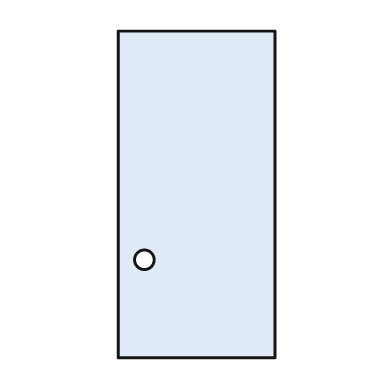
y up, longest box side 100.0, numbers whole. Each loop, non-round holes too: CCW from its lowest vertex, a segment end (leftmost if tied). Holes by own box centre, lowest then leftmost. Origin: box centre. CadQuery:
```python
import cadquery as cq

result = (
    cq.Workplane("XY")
    .moveTo(-24.0, -50.0)
    .lineTo(24.0, -50.0)
    .lineTo(24.0, 50.0)
    .lineTo(-24.0, 50.0)
    .close()
    .moveTo(-16.0, -20.0)
    .circle(3.0)
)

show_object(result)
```